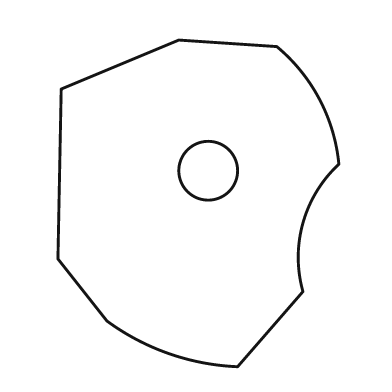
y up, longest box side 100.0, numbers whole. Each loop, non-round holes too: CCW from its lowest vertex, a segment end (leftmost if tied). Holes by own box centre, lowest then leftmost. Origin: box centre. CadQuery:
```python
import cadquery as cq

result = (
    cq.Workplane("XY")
    .moveTo(12.0, -50.0)
    .lineTo(32.0, -27.0)
    .threePointArc((32.0, -6.0), (43.0, 12.0))
    .threePointArc((37.0, 32.0), (24.0, 48.0))
    .lineTo(-6.0, 50.0)
    .lineTo(-42.0, 35.0)
    .lineTo(-43.0, -17.0)
    .lineTo(-28.0, -36.0)
    .threePointArc((-9.0, -46.0), (12.0, -50.0))
    .close()
    .moveTo(3.0, 10.0)
    .circle(9.0)
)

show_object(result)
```